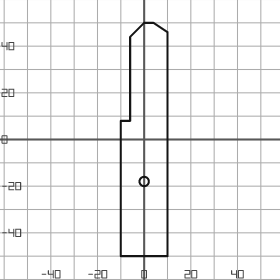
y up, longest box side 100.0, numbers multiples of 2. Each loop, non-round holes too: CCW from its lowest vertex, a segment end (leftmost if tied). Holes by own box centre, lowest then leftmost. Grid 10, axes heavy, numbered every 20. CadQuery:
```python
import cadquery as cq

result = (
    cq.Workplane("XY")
    .moveTo(-10.0, -50.0)
    .lineTo(10.0, -50.0)
    .lineTo(10.0, 46.0)
    .lineTo(4.0, 50.0)
    .lineTo(0.0, 50.0)
    .lineTo(-6.0, 44.0)
    .lineTo(-6.0, 8.0)
    .lineTo(-10.0, 8.0)
    .close()
    .moveTo(0.0, -18.0)
    .circle(2.0)
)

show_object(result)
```